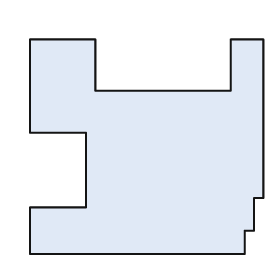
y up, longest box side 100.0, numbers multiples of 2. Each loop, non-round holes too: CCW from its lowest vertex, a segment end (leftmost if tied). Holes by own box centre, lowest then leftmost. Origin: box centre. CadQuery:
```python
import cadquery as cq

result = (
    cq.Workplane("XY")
    .moveTo(-50.0, -46.0)
    .lineTo(42.0, -46.0)
    .lineTo(42.0, -36.0)
    .lineTo(46.0, -36.0)
    .lineTo(46.0, -22.0)
    .lineTo(50.0, -22.0)
    .lineTo(50.0, 46.0)
    .lineTo(36.0, 46.0)
    .lineTo(36.0, 24.0)
    .lineTo(-22.0, 24.0)
    .lineTo(-22.0, 46.0)
    .lineTo(-50.0, 46.0)
    .lineTo(-50.0, 6.0)
    .lineTo(-26.0, 6.0)
    .lineTo(-26.0, -26.0)
    .lineTo(-50.0, -26.0)
    .close()
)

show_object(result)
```